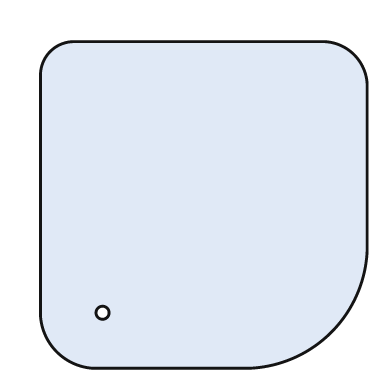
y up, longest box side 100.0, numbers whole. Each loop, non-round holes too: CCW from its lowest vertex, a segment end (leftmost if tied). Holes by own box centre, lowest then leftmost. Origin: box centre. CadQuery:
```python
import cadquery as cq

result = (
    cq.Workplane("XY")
    .moveTo(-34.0, -50.0)
    .lineTo(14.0, -50.0)
    .threePointArc((39.0, -39.0), (50.0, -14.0))
    .lineTo(50.0, 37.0)
    .threePointArc((46.0, 46.0), (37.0, 50.0))
    .lineTo(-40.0, 50.0)
    .threePointArc((-47.0, 47.0), (-50.0, 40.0))
    .lineTo(-50.0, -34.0)
    .threePointArc((-45.0, -45.0), (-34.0, -50.0))
    .close()
    .moveTo(-31.0, -33.0)
    .circle(2.0)
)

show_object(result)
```